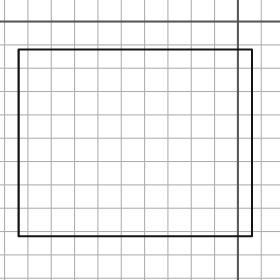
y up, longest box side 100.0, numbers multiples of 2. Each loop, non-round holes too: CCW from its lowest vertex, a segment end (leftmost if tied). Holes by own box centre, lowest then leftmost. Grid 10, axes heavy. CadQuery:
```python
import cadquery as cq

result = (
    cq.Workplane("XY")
    .moveTo(-94.0, -92.0)
    .lineTo(6.0, -92.0)
    .lineTo(6.0, -12.0)
    .lineTo(-94.0, -12.0)
    .close()
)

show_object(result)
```